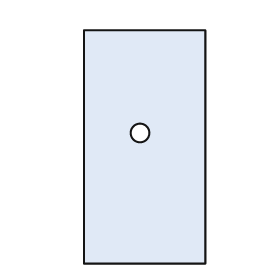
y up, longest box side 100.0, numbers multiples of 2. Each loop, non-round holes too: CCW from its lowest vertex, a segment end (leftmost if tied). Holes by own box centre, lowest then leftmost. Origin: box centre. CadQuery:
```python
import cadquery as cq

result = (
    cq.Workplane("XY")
    .moveTo(-26.0, -50.0)
    .lineTo(26.0, -50.0)
    .lineTo(26.0, 50.0)
    .lineTo(-26.0, 50.0)
    .close()
    .moveTo(-2.0, 6.0)
    .circle(4.0)
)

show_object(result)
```